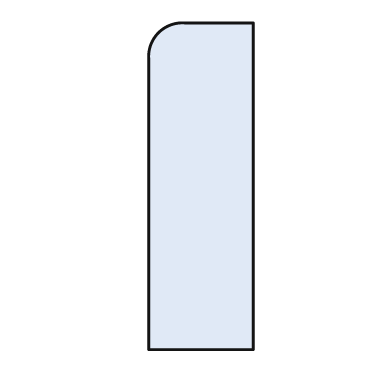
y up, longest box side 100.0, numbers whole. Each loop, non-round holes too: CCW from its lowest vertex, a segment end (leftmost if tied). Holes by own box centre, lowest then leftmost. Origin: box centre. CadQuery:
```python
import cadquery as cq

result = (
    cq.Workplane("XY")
    .moveTo(-16.0, -50.0)
    .lineTo(16.0, -50.0)
    .lineTo(16.0, 50.0)
    .lineTo(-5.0, 50.0)
    .threePointArc((-13.0, 47.0), (-16.0, 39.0))
    .close()
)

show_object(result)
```